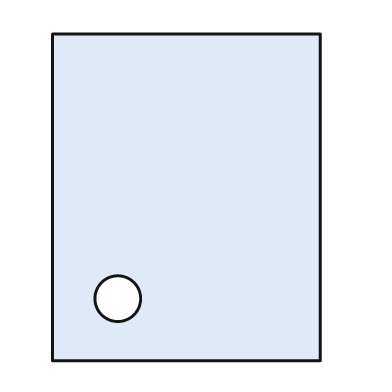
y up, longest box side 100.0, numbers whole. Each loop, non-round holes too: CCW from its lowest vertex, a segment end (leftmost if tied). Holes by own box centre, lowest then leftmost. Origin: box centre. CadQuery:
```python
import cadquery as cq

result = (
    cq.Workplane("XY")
    .moveTo(-41.0, -50.0)
    .lineTo(41.0, -50.0)
    .lineTo(41.0, 50.0)
    .lineTo(-41.0, 50.0)
    .close()
    .moveTo(-21.0, -31.0)
    .circle(7.0)
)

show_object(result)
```